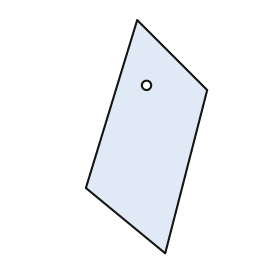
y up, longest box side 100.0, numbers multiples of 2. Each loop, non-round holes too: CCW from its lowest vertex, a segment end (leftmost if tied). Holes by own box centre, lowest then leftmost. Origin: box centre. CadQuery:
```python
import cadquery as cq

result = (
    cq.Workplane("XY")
    .moveTo(8.0, -50.0)
    .lineTo(26.0, 20.0)
    .lineTo(-4.0, 50.0)
    .lineTo(-26.0, -22.0)
    .close()
    .moveTo(0.0, 22.0)
    .circle(2.0)
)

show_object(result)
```